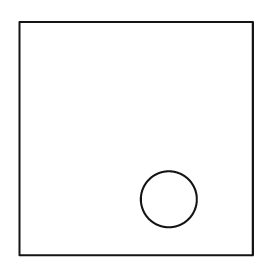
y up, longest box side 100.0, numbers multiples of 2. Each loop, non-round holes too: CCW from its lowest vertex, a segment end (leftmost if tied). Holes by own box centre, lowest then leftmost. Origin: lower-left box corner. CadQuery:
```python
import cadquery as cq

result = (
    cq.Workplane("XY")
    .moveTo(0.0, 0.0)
    .lineTo(100.0, 0.0)
    .lineTo(100.0, 100.0)
    .lineTo(0.0, 100.0)
    .close()
    .moveTo(64.0, 24.0)
    .circle(12.0)
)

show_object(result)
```